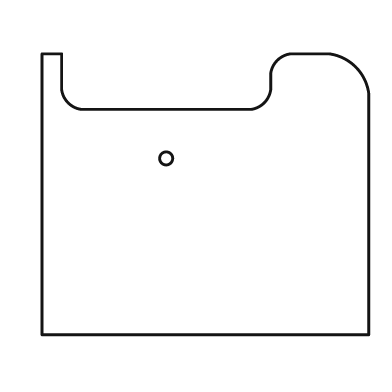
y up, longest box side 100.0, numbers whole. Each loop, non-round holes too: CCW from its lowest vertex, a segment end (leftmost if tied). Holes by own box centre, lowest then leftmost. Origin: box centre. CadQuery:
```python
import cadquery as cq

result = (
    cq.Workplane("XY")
    .moveTo(-50.0, -43.0)
    .lineTo(50.0, -43.0)
    .lineTo(50.0, 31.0)
    .threePointArc((46.0, 39.0), (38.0, 43.0))
    .lineTo(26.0, 43.0)
    .threePointArc((22.0, 41.0), (20.0, 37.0))
    .lineTo(20.0, 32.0)
    .threePointArc((18.0, 28.0), (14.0, 26.0))
    .lineTo(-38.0, 26.0)
    .threePointArc((-42.0, 28.0), (-44.0, 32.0))
    .lineTo(-44.0, 43.0)
    .lineTo(-50.0, 43.0)
    .close()
    .moveTo(-12.0, 11.0)
    .circle(2.0)
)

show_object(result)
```